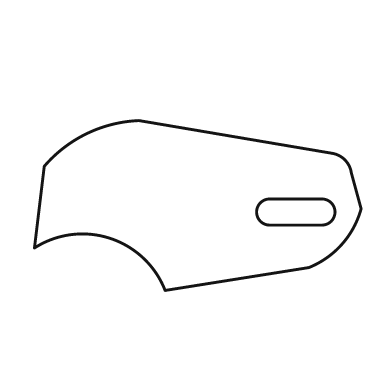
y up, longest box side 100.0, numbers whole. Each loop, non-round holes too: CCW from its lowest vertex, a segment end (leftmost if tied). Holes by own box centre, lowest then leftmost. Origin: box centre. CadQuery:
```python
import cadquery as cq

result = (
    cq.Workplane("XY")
    .moveTo(-10.0, -26.0)
    .lineTo(34.0, -19.0)
    .threePointArc((44.0, -12.0), (50.0, -1.0))
    .lineTo(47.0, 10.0)
    .threePointArc((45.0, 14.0), (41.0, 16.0))
    .lineTo(-18.0, 26.0)
    .threePointArc((-34.0, 22.0), (-47.0, 12.0))
    .lineTo(-50.0, -13.0)
    .threePointArc((-27.0, -10.0), (-10.0, -26.0))
    .close()
    .moveTo(22.0, -6.0)
    .lineTo(38.0, -6.0)
    .threePointArc((42.0, -2.0), (38.0, 2.0))
    .lineTo(22.0, 2.0)
    .threePointArc((18.0, -2.0), (22.0, -6.0))
    .close()
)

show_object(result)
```